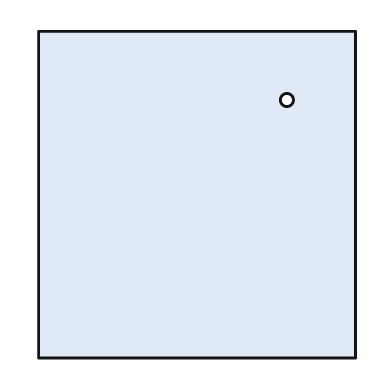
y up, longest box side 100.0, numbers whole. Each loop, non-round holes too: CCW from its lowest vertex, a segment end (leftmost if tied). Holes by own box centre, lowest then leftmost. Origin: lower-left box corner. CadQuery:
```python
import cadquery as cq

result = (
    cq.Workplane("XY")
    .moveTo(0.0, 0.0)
    .lineTo(97.0, 0.0)
    .lineTo(97.0, 100.0)
    .lineTo(0.0, 100.0)
    .close()
    .moveTo(76.0, 79.0)
    .circle(2.0)
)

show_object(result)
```